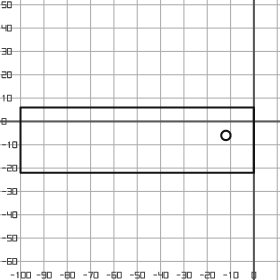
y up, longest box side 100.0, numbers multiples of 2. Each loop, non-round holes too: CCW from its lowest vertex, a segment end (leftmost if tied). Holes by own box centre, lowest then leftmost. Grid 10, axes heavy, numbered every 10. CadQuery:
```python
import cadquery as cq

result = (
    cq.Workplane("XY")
    .moveTo(-100.0, -22.0)
    .lineTo(0.0, -22.0)
    .lineTo(0.0, 6.0)
    .lineTo(-100.0, 6.0)
    .close()
    .moveTo(-12.0, -6.0)
    .circle(2.0)
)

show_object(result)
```